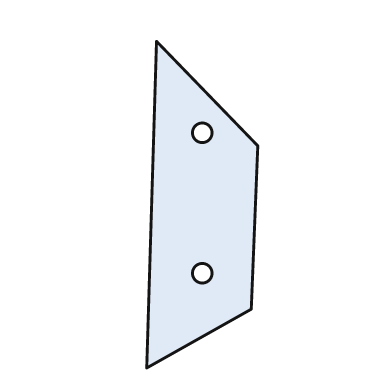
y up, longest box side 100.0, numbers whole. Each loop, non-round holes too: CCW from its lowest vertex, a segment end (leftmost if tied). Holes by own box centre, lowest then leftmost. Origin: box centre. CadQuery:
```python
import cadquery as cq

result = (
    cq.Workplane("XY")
    .moveTo(-17.0, -50.0)
    .lineTo(15.0, -32.0)
    .lineTo(17.0, 18.0)
    .lineTo(-14.0, 50.0)
    .close()
    .moveTo(0.0, -21.0)
    .circle(3.0)
    .moveTo(0.0, 22.0)
    .circle(3.0)
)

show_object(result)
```